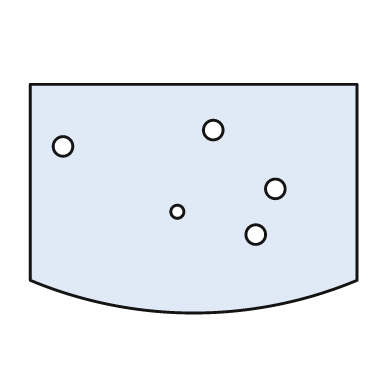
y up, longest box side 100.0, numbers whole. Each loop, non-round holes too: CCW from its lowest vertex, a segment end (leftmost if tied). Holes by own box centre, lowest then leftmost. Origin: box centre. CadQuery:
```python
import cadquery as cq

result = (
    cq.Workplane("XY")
    .moveTo(-50.0, -25.0)
    .threePointArc((0.0, -35.0), (50.0, -25.0))
    .lineTo(50.0, 35.0)
    .lineTo(-50.0, 35.0)
    .close()
    .moveTo(19.0, -11.0)
    .circle(3.0)
    .moveTo(-5.0, -4.0)
    .circle(2.0)
    .moveTo(25.0, 3.0)
    .circle(3.0)
    .moveTo(-40.0, 16.0)
    .circle(3.0)
    .moveTo(6.0, 21.0)
    .circle(3.0)
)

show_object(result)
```